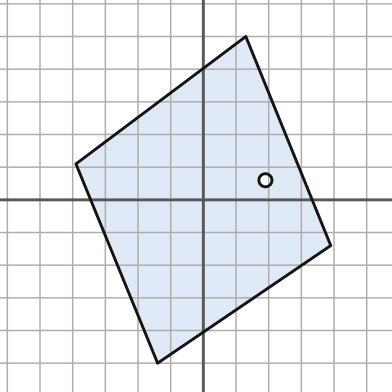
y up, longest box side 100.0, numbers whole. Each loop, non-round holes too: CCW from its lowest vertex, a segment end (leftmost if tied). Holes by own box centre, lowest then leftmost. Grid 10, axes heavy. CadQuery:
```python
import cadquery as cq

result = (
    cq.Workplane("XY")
    .moveTo(-14.0, -50.0)
    .lineTo(39.0, -14.0)
    .lineTo(13.0, 50.0)
    .lineTo(-39.0, 11.0)
    .close()
    .moveTo(19.0, 6.0)
    .circle(2.0)
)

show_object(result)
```